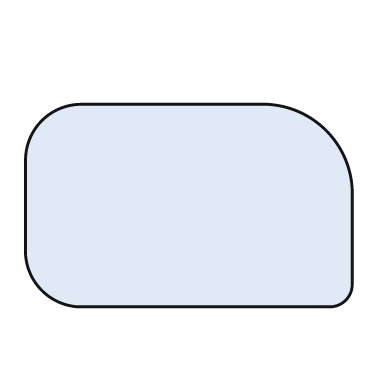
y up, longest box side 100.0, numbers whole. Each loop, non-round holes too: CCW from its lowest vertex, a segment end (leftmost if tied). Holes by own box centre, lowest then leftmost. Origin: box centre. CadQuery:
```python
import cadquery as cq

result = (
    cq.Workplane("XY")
    .moveTo(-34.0, -31.0)
    .lineTo(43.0, -31.0)
    .threePointArc((48.0, -29.0), (50.0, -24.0))
    .lineTo(50.0, 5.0)
    .threePointArc((42.0, 23.0), (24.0, 31.0))
    .lineTo(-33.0, 31.0)
    .threePointArc((-45.0, 26.0), (-50.0, 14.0))
    .lineTo(-50.0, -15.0)
    .threePointArc((-45.0, -26.0), (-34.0, -31.0))
    .close()
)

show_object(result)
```